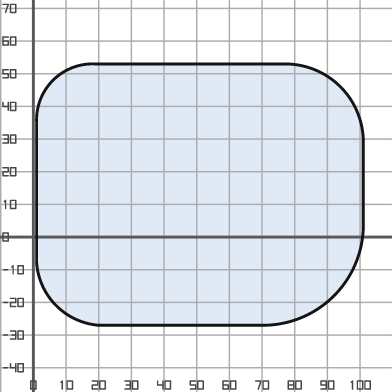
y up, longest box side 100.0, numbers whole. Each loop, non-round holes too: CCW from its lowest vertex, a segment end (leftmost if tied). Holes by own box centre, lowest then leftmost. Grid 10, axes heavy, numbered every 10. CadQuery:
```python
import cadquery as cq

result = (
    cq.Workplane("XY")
    .moveTo(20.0, -27.0)
    .lineTo(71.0, -27.0)
    .threePointArc((92.0, -18.0), (101.0, 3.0))
    .lineTo(101.0, 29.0)
    .threePointArc((94.0, 46.0), (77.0, 53.0))
    .lineTo(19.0, 53.0)
    .threePointArc((6.0, 48.0), (1.0, 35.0))
    .lineTo(1.0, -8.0)
    .threePointArc((7.0, -21.0), (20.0, -27.0))
    .close()
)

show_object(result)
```